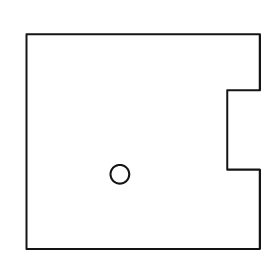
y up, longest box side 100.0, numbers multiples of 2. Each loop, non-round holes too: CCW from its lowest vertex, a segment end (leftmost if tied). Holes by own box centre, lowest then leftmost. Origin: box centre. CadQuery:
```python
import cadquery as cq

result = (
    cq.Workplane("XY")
    .moveTo(-50.0, -46.0)
    .lineTo(50.0, -46.0)
    .lineTo(50.0, -12.0)
    .lineTo(36.0, -12.0)
    .lineTo(36.0, 22.0)
    .lineTo(50.0, 22.0)
    .lineTo(50.0, 46.0)
    .lineTo(-50.0, 46.0)
    .close()
    .moveTo(-10.0, -14.0)
    .circle(4.0)
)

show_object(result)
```